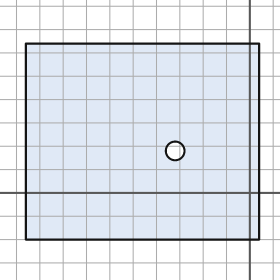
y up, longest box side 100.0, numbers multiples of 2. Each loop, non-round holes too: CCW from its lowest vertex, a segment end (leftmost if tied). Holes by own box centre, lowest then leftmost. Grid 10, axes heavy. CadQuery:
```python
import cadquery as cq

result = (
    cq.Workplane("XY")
    .moveTo(-96.0, -20.0)
    .lineTo(4.0, -20.0)
    .lineTo(4.0, 64.0)
    .lineTo(-96.0, 64.0)
    .close()
    .moveTo(-32.0, 18.0)
    .circle(4.0)
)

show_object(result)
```